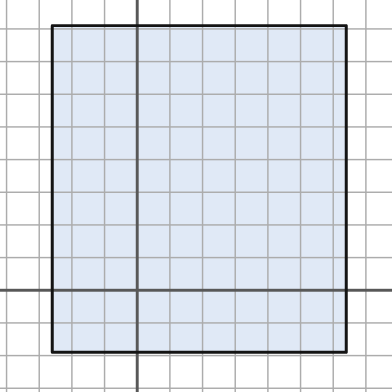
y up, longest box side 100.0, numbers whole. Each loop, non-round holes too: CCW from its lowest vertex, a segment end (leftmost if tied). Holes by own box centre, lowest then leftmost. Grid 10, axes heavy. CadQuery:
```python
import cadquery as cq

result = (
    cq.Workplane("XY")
    .moveTo(-26.0, -19.0)
    .lineTo(64.0, -19.0)
    .lineTo(64.0, 81.0)
    .lineTo(-26.0, 81.0)
    .close()
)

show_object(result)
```